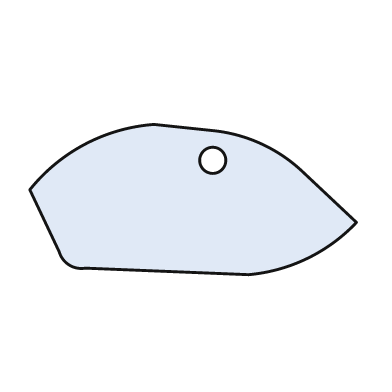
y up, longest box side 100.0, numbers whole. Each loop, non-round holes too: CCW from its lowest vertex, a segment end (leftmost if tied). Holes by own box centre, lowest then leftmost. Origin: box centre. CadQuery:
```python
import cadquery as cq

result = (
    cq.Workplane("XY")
    .moveTo(17.0, -23.0)
    .threePointArc((35.0, -18.0), (50.0, -7.0))
    .lineTo(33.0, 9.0)
    .threePointArc((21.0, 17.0), (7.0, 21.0))
    .lineTo(-12.0, 23.0)
    .threePointArc((-33.0, 17.0), (-50.0, 3.0))
    .lineTo(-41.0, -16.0)
    .threePointArc((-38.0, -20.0), (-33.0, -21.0))
    .close()
    .moveTo(6.0, 12.0)
    .circle(4.0)
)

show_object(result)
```